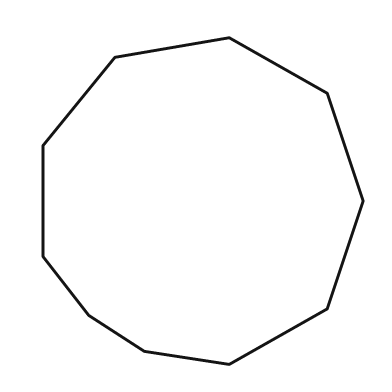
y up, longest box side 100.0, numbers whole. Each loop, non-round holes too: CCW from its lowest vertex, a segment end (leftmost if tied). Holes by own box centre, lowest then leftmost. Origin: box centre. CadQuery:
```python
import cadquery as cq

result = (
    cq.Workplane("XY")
    .moveTo(8.0, -50.0)
    .lineTo(38.0, -33.0)
    .lineTo(49.0, 0.0)
    .lineTo(38.0, 33.0)
    .lineTo(8.0, 50.0)
    .lineTo(-27.0, 44.0)
    .lineTo(-49.0, 17.0)
    .lineTo(-49.0, -17.0)
    .lineTo(-35.0, -35.0)
    .lineTo(-18.0, -46.0)
    .close()
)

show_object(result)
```